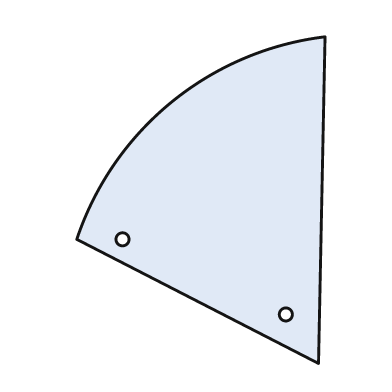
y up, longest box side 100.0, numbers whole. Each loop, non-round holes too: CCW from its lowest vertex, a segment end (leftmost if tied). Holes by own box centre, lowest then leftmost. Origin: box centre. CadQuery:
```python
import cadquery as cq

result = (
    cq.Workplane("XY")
    .moveTo(36.0, -50.0)
    .lineTo(38.0, 50.0)
    .threePointArc((-9.0, 30.0), (-38.0, -12.0))
    .close()
    .moveTo(26.0, -35.0)
    .circle(2.0)
    .moveTo(-24.0, -12.0)
    .circle(2.0)
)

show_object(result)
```